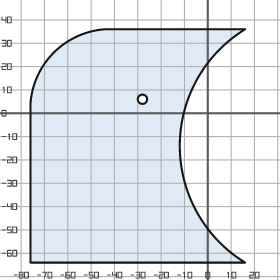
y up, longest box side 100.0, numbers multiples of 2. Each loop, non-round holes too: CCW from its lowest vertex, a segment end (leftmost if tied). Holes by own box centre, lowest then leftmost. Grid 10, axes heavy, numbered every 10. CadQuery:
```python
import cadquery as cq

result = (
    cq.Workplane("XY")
    .moveTo(-76.0, -64.0)
    .lineTo(16.0, -64.0)
    .threePointArc((-12.0, -14.0), (16.0, 36.0))
    .lineTo(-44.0, 36.0)
    .threePointArc((-66.0, 26.0), (-76.0, 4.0))
    .close()
    .moveTo(-28.0, 6.0)
    .circle(2.0)
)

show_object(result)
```